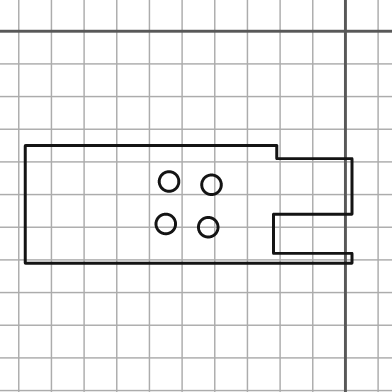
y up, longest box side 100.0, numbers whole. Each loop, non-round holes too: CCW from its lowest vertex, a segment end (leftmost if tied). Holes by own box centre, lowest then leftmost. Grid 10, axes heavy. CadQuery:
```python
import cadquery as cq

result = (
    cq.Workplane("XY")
    .moveTo(-98.0, -71.0)
    .lineTo(2.0, -71.0)
    .lineTo(2.0, -68.0)
    .lineTo(-22.0, -68.0)
    .lineTo(-22.0, -56.0)
    .lineTo(2.0, -56.0)
    .lineTo(2.0, -39.0)
    .lineTo(-21.0, -39.0)
    .lineTo(-21.0, -35.0)
    .lineTo(-98.0, -35.0)
    .close()
    .moveTo(-42.0, -60.0)
    .circle(3.0)
    .moveTo(-55.0, -59.0)
    .circle(3.0)
    .moveTo(-41.0, -47.0)
    .circle(3.0)
    .moveTo(-54.0, -46.0)
    .circle(3.0)
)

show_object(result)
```